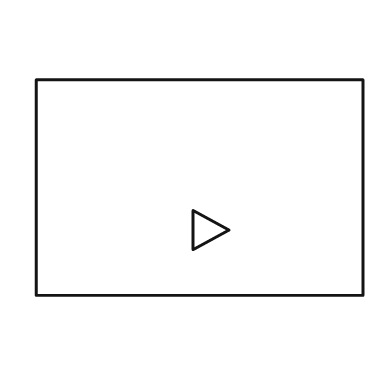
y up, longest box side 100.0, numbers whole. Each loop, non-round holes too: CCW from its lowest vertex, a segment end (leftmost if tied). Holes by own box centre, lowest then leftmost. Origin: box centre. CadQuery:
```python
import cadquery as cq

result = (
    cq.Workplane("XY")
    .moveTo(-50.0, -33.0)
    .lineTo(50.0, -33.0)
    .lineTo(50.0, 33.0)
    .lineTo(-50.0, 33.0)
    .close()
    .moveTo(-2.0, -19.0)
    .lineTo(9.0, -13.0)
    .lineTo(-2.0, -7.0)
    .close()
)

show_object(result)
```